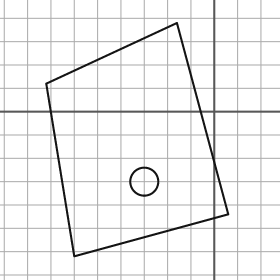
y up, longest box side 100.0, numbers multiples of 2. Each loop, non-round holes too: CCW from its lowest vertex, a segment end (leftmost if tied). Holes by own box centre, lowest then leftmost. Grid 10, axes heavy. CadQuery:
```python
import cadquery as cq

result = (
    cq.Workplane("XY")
    .moveTo(-60.0, -62.0)
    .lineTo(6.0, -44.0)
    .lineTo(-16.0, 38.0)
    .lineTo(-72.0, 12.0)
    .close()
    .moveTo(-30.0, -30.0)
    .circle(6.0)
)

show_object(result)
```